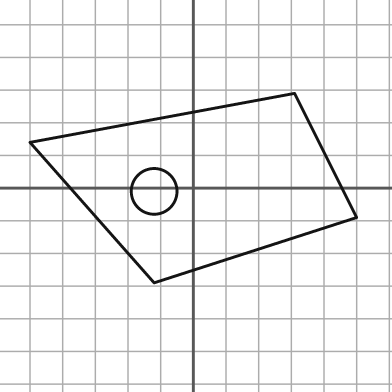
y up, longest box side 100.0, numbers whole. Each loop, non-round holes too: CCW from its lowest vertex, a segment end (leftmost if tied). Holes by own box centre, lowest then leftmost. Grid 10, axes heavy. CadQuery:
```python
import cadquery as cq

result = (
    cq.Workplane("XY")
    .moveTo(-12.0, -29.0)
    .lineTo(50.0, -9.0)
    .lineTo(31.0, 29.0)
    .lineTo(-50.0, 14.0)
    .close()
    .moveTo(-12.0, -1.0)
    .circle(7.0)
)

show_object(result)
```